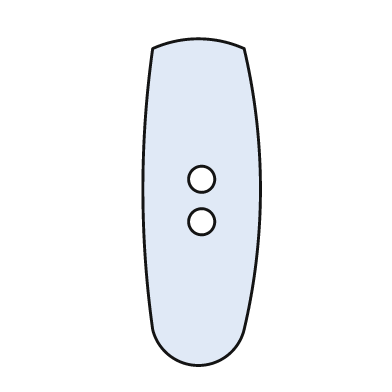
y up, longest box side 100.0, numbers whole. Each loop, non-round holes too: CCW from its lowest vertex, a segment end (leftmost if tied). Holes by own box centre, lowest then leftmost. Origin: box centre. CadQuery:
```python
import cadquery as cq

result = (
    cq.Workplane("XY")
    .moveTo(-15.0, -39.0)
    .threePointArc((-1.0, -50.0), (13.0, -39.0))
    .threePointArc((18.0, 4.0), (13.0, 47.0))
    .threePointArc((-1.0, 50.0), (-15.0, 47.0))
    .threePointArc((-18.0, 4.0), (-15.0, -39.0))
    .close()
    .moveTo(0.0, -6.0)
    .circle(4.0)
    .moveTo(0.0, 7.0)
    .circle(4.0)
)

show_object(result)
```